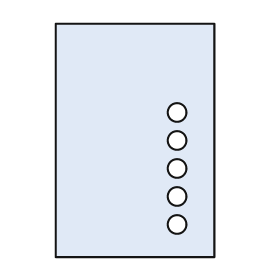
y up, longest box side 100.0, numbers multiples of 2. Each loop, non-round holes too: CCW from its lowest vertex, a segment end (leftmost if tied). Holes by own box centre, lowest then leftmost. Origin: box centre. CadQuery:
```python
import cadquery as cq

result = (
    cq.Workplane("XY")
    .moveTo(-34.0, -50.0)
    .lineTo(34.0, -50.0)
    .lineTo(34.0, 50.0)
    .lineTo(-34.0, 50.0)
    .close()
    .moveTo(18.0, -36.0)
    .circle(4.0)
    .moveTo(18.0, -24.0)
    .circle(4.0)
    .moveTo(18.0, -12.0)
    .circle(4.0)
    .moveTo(18.0, 0.0)
    .circle(4.0)
    .moveTo(18.0, 12.0)
    .circle(4.0)
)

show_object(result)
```